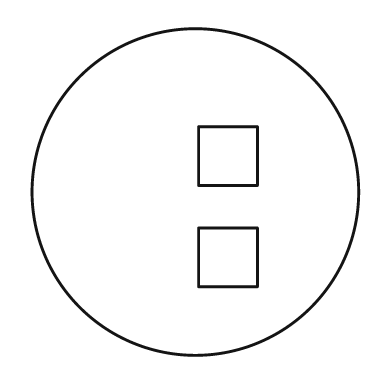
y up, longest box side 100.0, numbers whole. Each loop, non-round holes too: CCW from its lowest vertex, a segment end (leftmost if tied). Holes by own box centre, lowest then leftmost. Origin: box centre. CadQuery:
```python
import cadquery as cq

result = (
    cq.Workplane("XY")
    .moveTo(0.0, 0.0)
    .circle(50.0)
    .moveTo(1.0, -29.0)
    .lineTo(19.0, -29.0)
    .lineTo(19.0, -11.0)
    .lineTo(1.0, -11.0)
    .close()
    .moveTo(1.0, 2.0)
    .lineTo(19.0, 2.0)
    .lineTo(19.0, 20.0)
    .lineTo(1.0, 20.0)
    .close()
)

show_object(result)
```